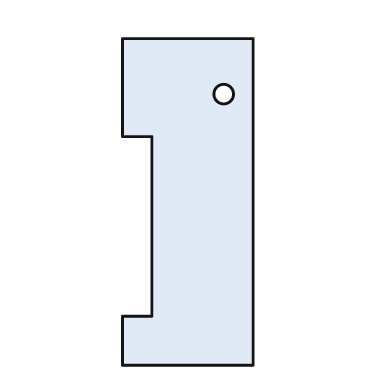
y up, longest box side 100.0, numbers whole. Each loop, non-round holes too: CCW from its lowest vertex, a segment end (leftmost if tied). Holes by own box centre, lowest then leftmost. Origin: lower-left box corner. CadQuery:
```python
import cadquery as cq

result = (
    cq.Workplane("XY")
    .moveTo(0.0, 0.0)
    .lineTo(40.0, 0.0)
    .lineTo(40.0, 100.0)
    .lineTo(0.0, 100.0)
    .lineTo(0.0, 70.0)
    .lineTo(9.0, 70.0)
    .lineTo(9.0, 15.0)
    .lineTo(0.0, 15.0)
    .close()
    .moveTo(31.0, 83.0)
    .circle(3.0)
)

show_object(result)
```